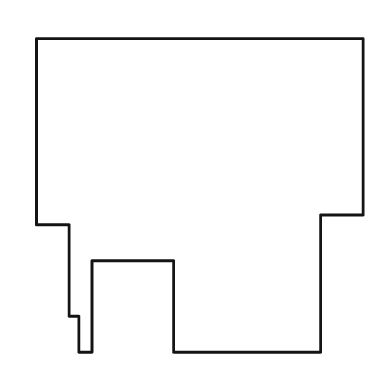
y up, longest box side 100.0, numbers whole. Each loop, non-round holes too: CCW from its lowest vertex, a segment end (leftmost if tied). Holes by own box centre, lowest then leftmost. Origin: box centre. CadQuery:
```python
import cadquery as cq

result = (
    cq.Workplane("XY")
    .moveTo(-37.0, -48.0)
    .lineTo(-33.0, -48.0)
    .lineTo(-33.0, -20.0)
    .lineTo(-8.0, -20.0)
    .lineTo(-8.0, -48.0)
    .lineTo(37.0, -48.0)
    .lineTo(37.0, -6.0)
    .lineTo(50.0, -6.0)
    .lineTo(50.0, 48.0)
    .lineTo(-50.0, 48.0)
    .lineTo(-50.0, -9.0)
    .lineTo(-40.0, -9.0)
    .lineTo(-40.0, -37.0)
    .lineTo(-37.0, -37.0)
    .close()
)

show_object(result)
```